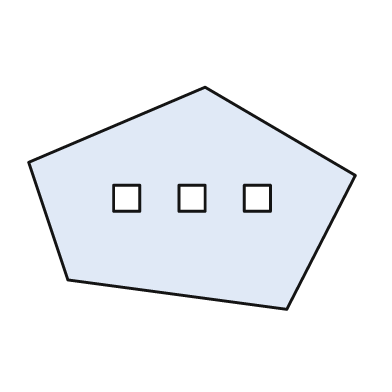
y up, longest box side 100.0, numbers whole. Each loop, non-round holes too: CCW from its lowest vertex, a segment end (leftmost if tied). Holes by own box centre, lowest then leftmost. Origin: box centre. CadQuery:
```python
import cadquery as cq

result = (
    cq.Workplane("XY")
    .moveTo(29.0, -34.0)
    .lineTo(50.0, 7.0)
    .lineTo(4.0, 34.0)
    .lineTo(-50.0, 11.0)
    .lineTo(-38.0, -25.0)
    .close()
    .moveTo(-24.0, -4.0)
    .lineTo(-16.0, -4.0)
    .lineTo(-16.0, 4.0)
    .lineTo(-24.0, 4.0)
    .close()
    .moveTo(-4.0, -4.0)
    .lineTo(4.0, -4.0)
    .lineTo(4.0, 4.0)
    .lineTo(-4.0, 4.0)
    .close()
    .moveTo(16.0, -4.0)
    .lineTo(24.0, -4.0)
    .lineTo(24.0, 4.0)
    .lineTo(16.0, 4.0)
    .close()
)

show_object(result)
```